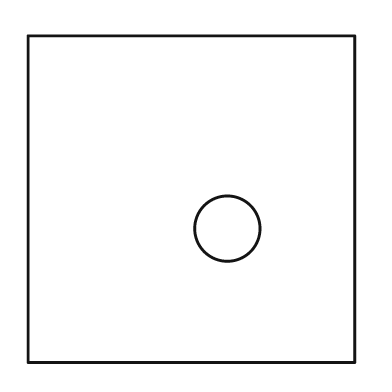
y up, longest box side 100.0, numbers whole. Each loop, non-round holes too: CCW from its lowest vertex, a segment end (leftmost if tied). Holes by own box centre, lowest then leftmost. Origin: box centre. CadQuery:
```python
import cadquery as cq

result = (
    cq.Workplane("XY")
    .moveTo(-50.0, -50.0)
    .lineTo(50.0, -50.0)
    .lineTo(50.0, 50.0)
    .lineTo(-50.0, 50.0)
    .close()
    .moveTo(11.0, -9.0)
    .circle(10.0)
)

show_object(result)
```